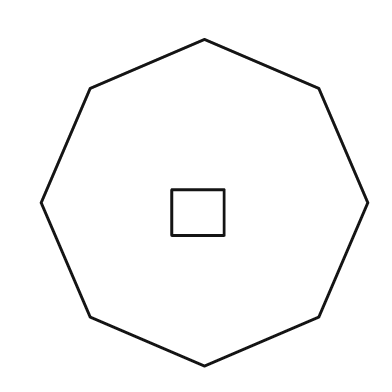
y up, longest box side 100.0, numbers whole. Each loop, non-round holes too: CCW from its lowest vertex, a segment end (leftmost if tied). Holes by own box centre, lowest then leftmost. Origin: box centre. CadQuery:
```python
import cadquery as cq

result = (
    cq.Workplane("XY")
    .moveTo(0.0, -50.0)
    .lineTo(35.0, -35.0)
    .lineTo(50.0, 0.0)
    .lineTo(35.0, 35.0)
    .lineTo(0.0, 50.0)
    .lineTo(-35.0, 35.0)
    .lineTo(-50.0, 0.0)
    .lineTo(-35.0, -35.0)
    .close()
    .moveTo(-10.0, -10.0)
    .lineTo(6.0, -10.0)
    .lineTo(6.0, 4.0)
    .lineTo(-10.0, 4.0)
    .close()
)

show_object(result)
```